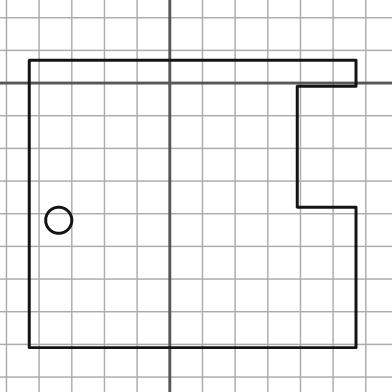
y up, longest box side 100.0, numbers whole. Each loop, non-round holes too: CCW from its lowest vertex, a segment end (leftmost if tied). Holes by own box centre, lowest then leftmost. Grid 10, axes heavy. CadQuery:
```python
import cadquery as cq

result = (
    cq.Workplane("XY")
    .moveTo(-43.0, -81.0)
    .lineTo(57.0, -81.0)
    .lineTo(57.0, -38.0)
    .lineTo(39.0, -38.0)
    .lineTo(39.0, -1.0)
    .lineTo(57.0, -1.0)
    .lineTo(57.0, 7.0)
    .lineTo(-43.0, 7.0)
    .close()
    .moveTo(-34.0, -42.0)
    .circle(4.0)
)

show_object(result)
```